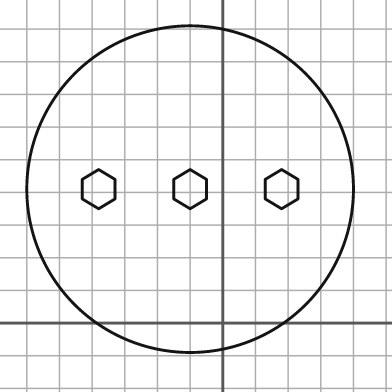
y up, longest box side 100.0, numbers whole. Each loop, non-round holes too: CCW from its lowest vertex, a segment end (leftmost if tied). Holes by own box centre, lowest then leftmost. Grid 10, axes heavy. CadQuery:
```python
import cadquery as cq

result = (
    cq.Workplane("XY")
    .moveTo(-10.0, 41.0)
    .circle(50.0)
    .moveTo(-38.0, 35.0)
    .lineTo(-33.0, 38.0)
    .lineTo(-33.0, 44.0)
    .lineTo(-38.0, 47.0)
    .lineTo(-43.0, 44.0)
    .lineTo(-43.0, 38.0)
    .close()
    .moveTo(-10.0, 35.0)
    .lineTo(-5.0, 38.0)
    .lineTo(-5.0, 44.0)
    .lineTo(-10.0, 47.0)
    .lineTo(-15.0, 44.0)
    .lineTo(-15.0, 38.0)
    .close()
    .moveTo(18.0, 35.0)
    .lineTo(23.0, 38.0)
    .lineTo(23.0, 44.0)
    .lineTo(18.0, 47.0)
    .lineTo(13.0, 44.0)
    .lineTo(13.0, 38.0)
    .close()
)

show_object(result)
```